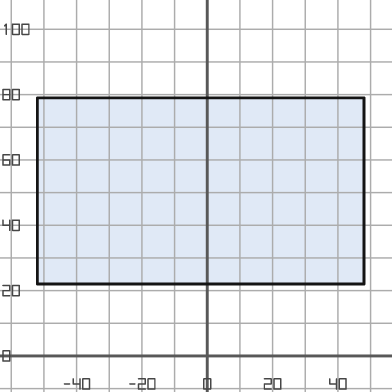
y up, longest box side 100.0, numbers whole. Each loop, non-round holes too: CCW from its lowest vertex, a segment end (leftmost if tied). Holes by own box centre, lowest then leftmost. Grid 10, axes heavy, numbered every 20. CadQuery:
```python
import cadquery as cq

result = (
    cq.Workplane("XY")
    .moveTo(-52.0, 22.0)
    .lineTo(48.0, 22.0)
    .lineTo(48.0, 79.0)
    .lineTo(-52.0, 79.0)
    .close()
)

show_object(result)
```